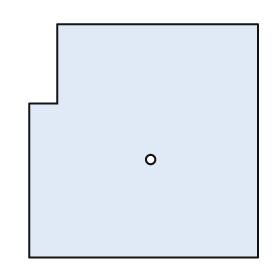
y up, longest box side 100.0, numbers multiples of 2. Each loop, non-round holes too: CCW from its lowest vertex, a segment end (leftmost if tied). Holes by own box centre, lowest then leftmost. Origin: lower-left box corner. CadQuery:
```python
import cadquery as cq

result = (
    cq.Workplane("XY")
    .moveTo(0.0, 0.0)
    .lineTo(98.0, 0.0)
    .lineTo(98.0, 100.0)
    .lineTo(12.0, 100.0)
    .lineTo(12.0, 66.0)
    .lineTo(0.0, 66.0)
    .close()
    .moveTo(52.0, 42.0)
    .circle(2.0)
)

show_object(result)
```